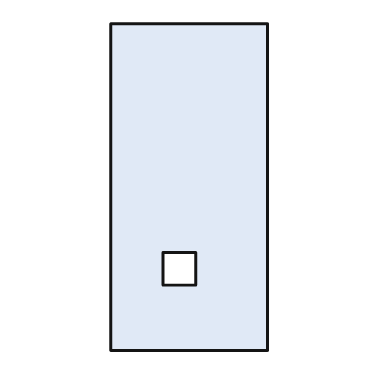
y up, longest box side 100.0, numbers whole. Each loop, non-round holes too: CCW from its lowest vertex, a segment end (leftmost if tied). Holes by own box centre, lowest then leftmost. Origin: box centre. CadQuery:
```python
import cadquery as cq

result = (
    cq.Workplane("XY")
    .moveTo(-24.0, -50.0)
    .lineTo(24.0, -50.0)
    .lineTo(24.0, 50.0)
    .lineTo(-24.0, 50.0)
    .close()
    .moveTo(-8.0, -30.0)
    .lineTo(2.0, -30.0)
    .lineTo(2.0, -20.0)
    .lineTo(-8.0, -20.0)
    .close()
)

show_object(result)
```